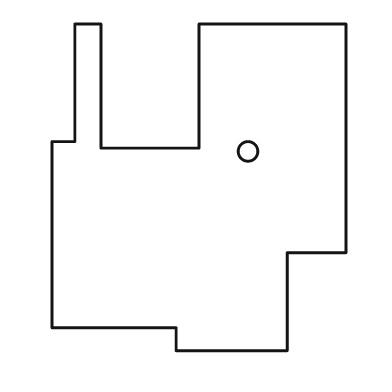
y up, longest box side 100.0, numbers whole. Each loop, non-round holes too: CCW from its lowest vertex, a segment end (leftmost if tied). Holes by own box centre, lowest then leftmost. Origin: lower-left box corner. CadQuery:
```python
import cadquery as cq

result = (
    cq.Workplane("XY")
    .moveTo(38.0, 0.0)
    .lineTo(72.0, 0.0)
    .lineTo(72.0, 30.0)
    .lineTo(90.0, 30.0)
    .lineTo(90.0, 100.0)
    .lineTo(45.0, 100.0)
    .lineTo(45.0, 62.0)
    .lineTo(15.0, 62.0)
    .lineTo(15.0, 100.0)
    .lineTo(7.0, 100.0)
    .lineTo(7.0, 64.0)
    .lineTo(0.0, 64.0)
    .lineTo(0.0, 7.0)
    .lineTo(38.0, 7.0)
    .close()
    .moveTo(60.0, 61.0)
    .circle(3.0)
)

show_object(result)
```